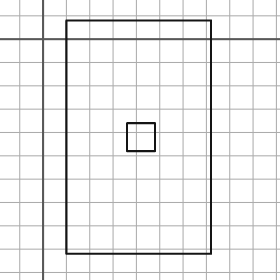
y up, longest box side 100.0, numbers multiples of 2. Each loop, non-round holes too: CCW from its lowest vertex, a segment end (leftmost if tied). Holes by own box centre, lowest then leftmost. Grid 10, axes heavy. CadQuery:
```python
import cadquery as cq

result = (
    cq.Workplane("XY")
    .moveTo(10.0, -92.0)
    .lineTo(72.0, -92.0)
    .lineTo(72.0, 8.0)
    .lineTo(10.0, 8.0)
    .close()
    .moveTo(36.0, -48.0)
    .lineTo(48.0, -48.0)
    .lineTo(48.0, -36.0)
    .lineTo(36.0, -36.0)
    .close()
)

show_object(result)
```